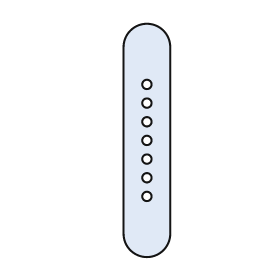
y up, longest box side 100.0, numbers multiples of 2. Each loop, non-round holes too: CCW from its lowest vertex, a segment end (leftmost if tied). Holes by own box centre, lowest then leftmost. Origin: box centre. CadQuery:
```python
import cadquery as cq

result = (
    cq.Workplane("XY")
    .moveTo(-10.0, -40.0)
    .threePointArc((0.0, -50.0), (10.0, -40.0))
    .lineTo(10.0, 40.0)
    .threePointArc((0.0, 50.0), (-10.0, 40.0))
    .close()
    .moveTo(0.0, -24.0)
    .circle(2.0)
    .moveTo(0.0, -16.0)
    .circle(2.0)
    .moveTo(0.0, -8.0)
    .circle(2.0)
    .moveTo(0.0, 0.0)
    .circle(2.0)
    .moveTo(0.0, 8.0)
    .circle(2.0)
    .moveTo(0.0, 16.0)
    .circle(2.0)
    .moveTo(0.0, 24.0)
    .circle(2.0)
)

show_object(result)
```